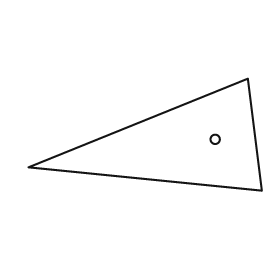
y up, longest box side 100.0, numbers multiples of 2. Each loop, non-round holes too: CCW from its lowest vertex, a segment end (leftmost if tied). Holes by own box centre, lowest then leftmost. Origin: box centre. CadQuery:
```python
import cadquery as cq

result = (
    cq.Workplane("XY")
    .moveTo(50.0, -24.0)
    .lineTo(44.0, 24.0)
    .lineTo(-50.0, -14.0)
    .close()
    .moveTo(30.0, -2.0)
    .circle(2.0)
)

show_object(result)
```